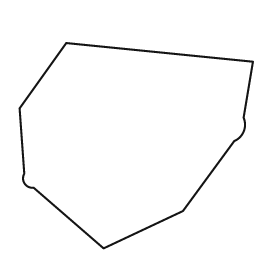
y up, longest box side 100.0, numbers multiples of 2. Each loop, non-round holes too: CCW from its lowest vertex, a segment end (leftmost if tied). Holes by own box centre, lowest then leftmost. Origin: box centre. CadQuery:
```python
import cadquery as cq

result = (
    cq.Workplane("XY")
    .moveTo(-14.0, -44.0)
    .lineTo(20.0, -28.0)
    .lineTo(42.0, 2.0)
    .threePointArc((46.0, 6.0), (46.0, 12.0))
    .lineTo(50.0, 36.0)
    .lineTo(-30.0, 44.0)
    .lineTo(-50.0, 16.0)
    .lineTo(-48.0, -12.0)
    .threePointArc((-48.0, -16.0), (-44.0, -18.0))
    .close()
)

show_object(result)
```